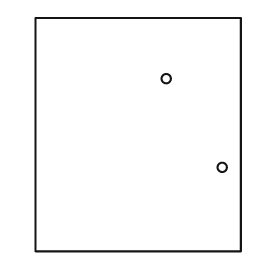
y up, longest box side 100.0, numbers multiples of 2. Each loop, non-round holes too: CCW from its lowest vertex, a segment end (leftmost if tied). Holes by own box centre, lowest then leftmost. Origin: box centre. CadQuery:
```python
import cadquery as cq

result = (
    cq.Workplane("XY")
    .moveTo(-44.0, -50.0)
    .lineTo(44.0, -50.0)
    .lineTo(44.0, 50.0)
    .lineTo(-44.0, 50.0)
    .close()
    .moveTo(36.0, -14.0)
    .circle(2.0)
    .moveTo(12.0, 24.0)
    .circle(2.0)
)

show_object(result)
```